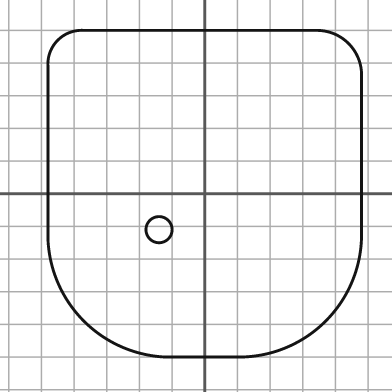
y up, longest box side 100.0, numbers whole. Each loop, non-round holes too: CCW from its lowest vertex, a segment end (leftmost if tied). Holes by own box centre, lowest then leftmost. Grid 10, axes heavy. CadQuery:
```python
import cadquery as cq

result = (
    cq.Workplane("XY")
    .moveTo(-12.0, -50.0)
    .lineTo(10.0, -50.0)
    .threePointArc((37.0, -39.0), (48.0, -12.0))
    .lineTo(48.0, 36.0)
    .threePointArc((44.0, 46.0), (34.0, 50.0))
    .lineTo(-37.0, 50.0)
    .threePointArc((-45.0, 47.0), (-48.0, 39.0))
    .lineTo(-48.0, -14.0)
    .threePointArc((-37.0, -39.0), (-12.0, -50.0))
    .close()
    .moveTo(-14.0, -11.0)
    .circle(4.0)
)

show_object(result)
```